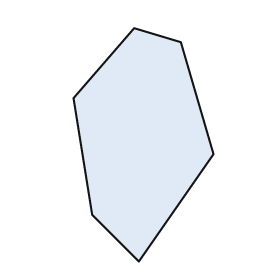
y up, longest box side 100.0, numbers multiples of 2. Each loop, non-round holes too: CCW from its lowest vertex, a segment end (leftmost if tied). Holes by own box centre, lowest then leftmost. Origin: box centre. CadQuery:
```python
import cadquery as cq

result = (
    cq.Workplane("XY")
    .moveTo(-2.0, -50.0)
    .lineTo(30.0, -4.0)
    .lineTo(16.0, 44.0)
    .lineTo(-4.0, 50.0)
    .lineTo(-30.0, 20.0)
    .lineTo(-22.0, -30.0)
    .close()
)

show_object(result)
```